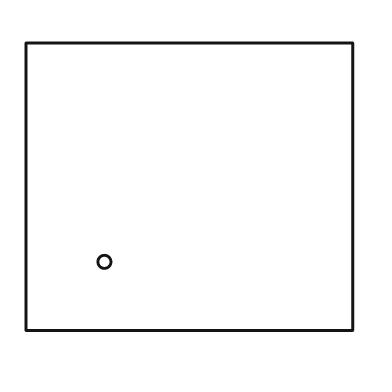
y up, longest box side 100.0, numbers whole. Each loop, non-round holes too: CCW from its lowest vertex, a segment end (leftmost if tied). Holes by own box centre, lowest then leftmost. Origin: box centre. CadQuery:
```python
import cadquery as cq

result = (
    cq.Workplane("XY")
    .moveTo(-50.0, -44.0)
    .lineTo(50.0, -44.0)
    .lineTo(50.0, 44.0)
    .lineTo(-50.0, 44.0)
    .close()
    .moveTo(-26.0, -23.0)
    .circle(2.0)
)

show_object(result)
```